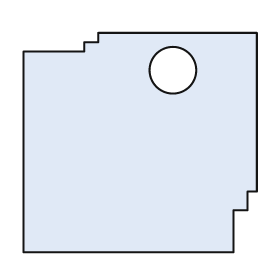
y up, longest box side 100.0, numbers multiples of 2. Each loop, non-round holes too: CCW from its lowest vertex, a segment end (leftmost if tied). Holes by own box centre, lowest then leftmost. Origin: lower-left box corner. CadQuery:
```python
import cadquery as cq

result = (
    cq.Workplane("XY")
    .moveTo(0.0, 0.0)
    .lineTo(90.0, 0.0)
    .lineTo(90.0, 18.0)
    .lineTo(96.0, 18.0)
    .lineTo(96.0, 26.0)
    .lineTo(100.0, 26.0)
    .lineTo(100.0, 94.0)
    .lineTo(32.0, 94.0)
    .lineTo(32.0, 90.0)
    .lineTo(26.0, 90.0)
    .lineTo(26.0, 86.0)
    .lineTo(0.0, 86.0)
    .close()
    .moveTo(64.0, 78.0)
    .circle(10.0)
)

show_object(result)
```